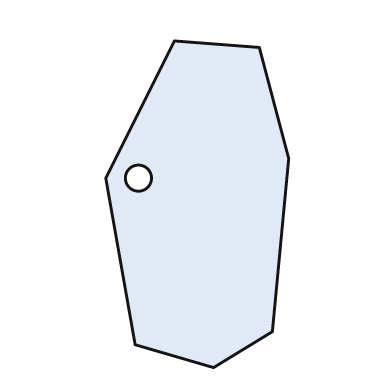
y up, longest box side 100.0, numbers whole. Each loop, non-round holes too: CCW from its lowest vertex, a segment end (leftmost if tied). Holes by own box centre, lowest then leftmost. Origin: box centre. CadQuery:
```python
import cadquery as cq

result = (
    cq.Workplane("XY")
    .moveTo(5.0, -50.0)
    .lineTo(23.0, -39.0)
    .lineTo(28.0, 14.0)
    .lineTo(19.0, 48.0)
    .lineTo(-7.0, 50.0)
    .lineTo(-28.0, 8.0)
    .lineTo(-19.0, -43.0)
    .close()
    .moveTo(-18.0, 8.0)
    .circle(4.0)
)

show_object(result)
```